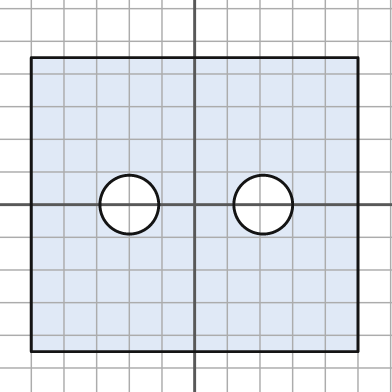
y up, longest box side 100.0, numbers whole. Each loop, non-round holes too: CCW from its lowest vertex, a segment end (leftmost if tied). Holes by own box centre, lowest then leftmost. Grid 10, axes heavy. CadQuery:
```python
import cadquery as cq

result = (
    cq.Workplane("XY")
    .moveTo(-50.0, -45.0)
    .lineTo(50.0, -45.0)
    .lineTo(50.0, 45.0)
    .lineTo(-50.0, 45.0)
    .close()
    .moveTo(-20.0, 0.0)
    .circle(9.0)
    .moveTo(21.0, 0.0)
    .circle(9.0)
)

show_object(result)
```